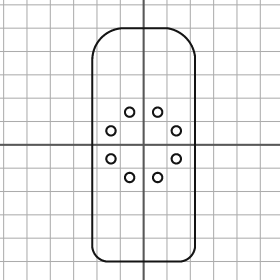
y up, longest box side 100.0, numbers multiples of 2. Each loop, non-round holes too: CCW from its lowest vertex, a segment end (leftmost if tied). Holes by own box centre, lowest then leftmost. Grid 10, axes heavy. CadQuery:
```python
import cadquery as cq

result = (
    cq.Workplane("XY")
    .moveTo(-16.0, -50.0)
    .lineTo(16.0, -50.0)
    .threePointArc((20.0, -48.0), (22.0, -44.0))
    .lineTo(22.0, 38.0)
    .threePointArc((18.0, 46.0), (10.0, 50.0))
    .lineTo(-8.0, 50.0)
    .threePointArc((-18.0, 46.0), (-22.0, 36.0))
    .lineTo(-22.0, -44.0)
    .threePointArc((-20.0, -48.0), (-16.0, -50.0))
    .close()
    .moveTo(-6.0, -14.0)
    .circle(2.0)
    .moveTo(6.0, -14.0)
    .circle(2.0)
    .moveTo(-14.0, -6.0)
    .circle(2.0)
    .moveTo(14.0, -6.0)
    .circle(2.0)
    .moveTo(-14.0, 6.0)
    .circle(2.0)
    .moveTo(14.0, 6.0)
    .circle(2.0)
    .moveTo(-6.0, 14.0)
    .circle(2.0)
    .moveTo(6.0, 14.0)
    .circle(2.0)
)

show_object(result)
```